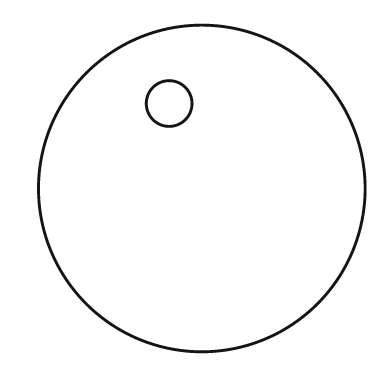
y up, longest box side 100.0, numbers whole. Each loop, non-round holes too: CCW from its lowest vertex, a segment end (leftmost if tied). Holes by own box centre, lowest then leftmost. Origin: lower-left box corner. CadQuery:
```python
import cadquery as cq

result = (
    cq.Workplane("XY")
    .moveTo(50.0, 50.0)
    .circle(50.0)
    .moveTo(40.0, 76.0)
    .circle(7.0)
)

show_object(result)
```